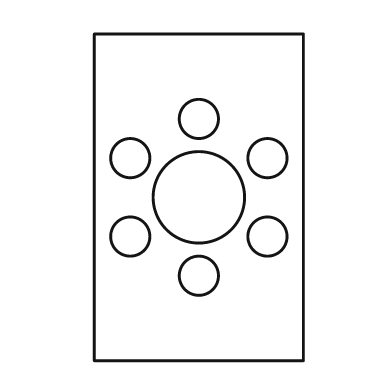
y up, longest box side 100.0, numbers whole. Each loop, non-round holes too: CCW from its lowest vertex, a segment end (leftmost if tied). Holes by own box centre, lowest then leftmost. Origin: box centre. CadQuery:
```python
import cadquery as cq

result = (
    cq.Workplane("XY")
    .moveTo(-32.0, -50.0)
    .lineTo(32.0, -50.0)
    .lineTo(32.0, 50.0)
    .lineTo(-32.0, 50.0)
    .close()
    .moveTo(0.0, -24.0)
    .circle(6.0)
    .moveTo(-21.0, -12.0)
    .circle(6.0)
    .moveTo(21.0, -12.0)
    .circle(6.0)
    .moveTo(0.0, 0.0)
    .circle(14.0)
    .moveTo(-21.0, 12.0)
    .circle(6.0)
    .moveTo(21.0, 12.0)
    .circle(6.0)
    .moveTo(0.0, 24.0)
    .circle(6.0)
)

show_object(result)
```